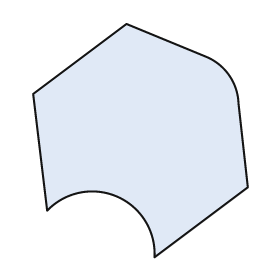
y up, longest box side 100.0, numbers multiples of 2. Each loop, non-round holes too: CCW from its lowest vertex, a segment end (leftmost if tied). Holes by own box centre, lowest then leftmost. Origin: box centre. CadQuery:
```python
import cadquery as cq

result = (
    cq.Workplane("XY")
    .moveTo(6.0, -50.0)
    .lineTo(46.0, -20.0)
    .lineTo(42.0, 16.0)
    .threePointArc((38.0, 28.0), (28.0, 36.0))
    .lineTo(-6.0, 50.0)
    .lineTo(-46.0, 20.0)
    .lineTo(-40.0, -30.0)
    .threePointArc((-10.0, -24.0), (6.0, -50.0))
    .close()
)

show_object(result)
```